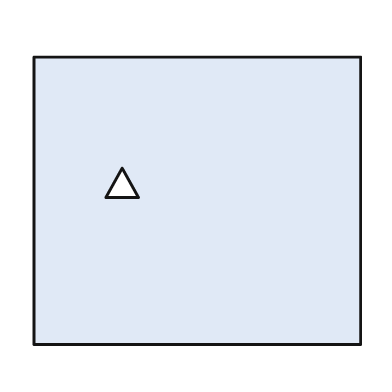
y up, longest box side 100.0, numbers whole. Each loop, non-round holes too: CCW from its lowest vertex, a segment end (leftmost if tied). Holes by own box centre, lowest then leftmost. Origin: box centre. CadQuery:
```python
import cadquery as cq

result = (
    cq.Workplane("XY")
    .moveTo(-50.0, -44.0)
    .lineTo(50.0, -44.0)
    .lineTo(50.0, 44.0)
    .lineTo(-50.0, 44.0)
    .close()
    .moveTo(-28.0, 1.0)
    .lineTo(-18.0, 1.0)
    .lineTo(-23.0, 10.0)
    .close()
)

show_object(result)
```